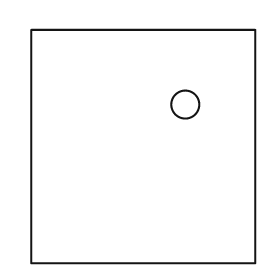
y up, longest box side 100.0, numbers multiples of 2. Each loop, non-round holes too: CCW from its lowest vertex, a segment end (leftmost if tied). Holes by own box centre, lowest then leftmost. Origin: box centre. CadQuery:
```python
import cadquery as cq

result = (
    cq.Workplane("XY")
    .moveTo(-48.0, -50.0)
    .lineTo(48.0, -50.0)
    .lineTo(48.0, 50.0)
    .lineTo(-48.0, 50.0)
    .close()
    .moveTo(18.0, 18.0)
    .circle(6.0)
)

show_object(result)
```